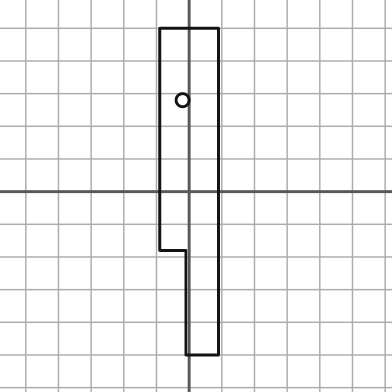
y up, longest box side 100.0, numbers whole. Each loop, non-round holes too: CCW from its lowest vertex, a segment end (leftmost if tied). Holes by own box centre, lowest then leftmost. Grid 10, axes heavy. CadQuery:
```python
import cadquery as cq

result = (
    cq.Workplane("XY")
    .moveTo(-1.0, -50.0)
    .lineTo(9.0, -50.0)
    .lineTo(9.0, 50.0)
    .lineTo(-9.0, 50.0)
    .lineTo(-9.0, -18.0)
    .lineTo(-1.0, -18.0)
    .close()
    .moveTo(-2.0, 28.0)
    .circle(2.0)
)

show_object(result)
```